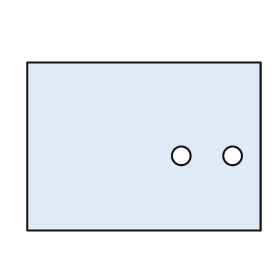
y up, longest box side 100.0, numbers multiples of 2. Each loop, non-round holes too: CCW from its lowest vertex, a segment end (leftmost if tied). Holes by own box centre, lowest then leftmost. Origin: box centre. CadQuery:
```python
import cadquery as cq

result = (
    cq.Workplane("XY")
    .moveTo(-50.0, -36.0)
    .lineTo(50.0, -36.0)
    .lineTo(50.0, 36.0)
    .lineTo(-50.0, 36.0)
    .close()
    .moveTo(16.0, -4.0)
    .circle(4.0)
    .moveTo(38.0, -4.0)
    .circle(4.0)
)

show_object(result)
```